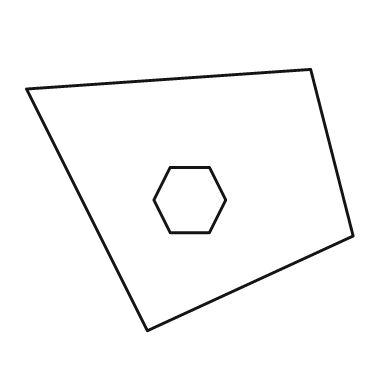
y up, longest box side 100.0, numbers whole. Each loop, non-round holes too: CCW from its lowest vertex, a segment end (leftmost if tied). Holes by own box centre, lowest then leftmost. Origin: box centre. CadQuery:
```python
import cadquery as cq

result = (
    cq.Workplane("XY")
    .moveTo(-13.0, -40.0)
    .lineTo(50.0, -11.0)
    .lineTo(37.0, 40.0)
    .lineTo(-50.0, 34.0)
    .close()
    .moveTo(-6.0, -10.0)
    .lineTo(6.0, -10.0)
    .lineTo(11.0, 0.0)
    .lineTo(6.0, 10.0)
    .lineTo(-6.0, 10.0)
    .lineTo(-11.0, 0.0)
    .close()
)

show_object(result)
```